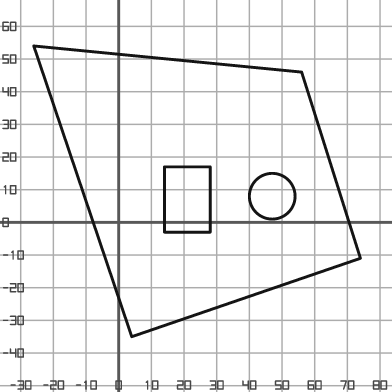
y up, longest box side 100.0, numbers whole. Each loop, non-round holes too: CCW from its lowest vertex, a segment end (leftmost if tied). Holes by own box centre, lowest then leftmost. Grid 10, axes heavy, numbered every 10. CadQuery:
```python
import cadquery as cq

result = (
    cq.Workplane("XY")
    .moveTo(4.0, -35.0)
    .lineTo(74.0, -11.0)
    .lineTo(56.0, 46.0)
    .lineTo(-26.0, 54.0)
    .close()
    .moveTo(14.0, -3.0)
    .lineTo(28.0, -3.0)
    .lineTo(28.0, 17.0)
    .lineTo(14.0, 17.0)
    .close()
    .moveTo(47.0, 8.0)
    .circle(7.0)
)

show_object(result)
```